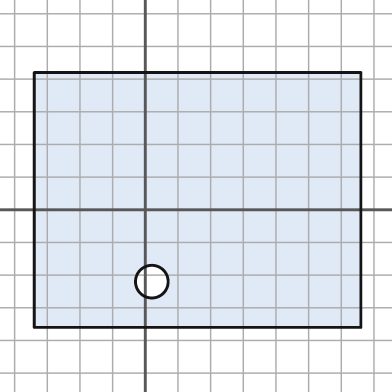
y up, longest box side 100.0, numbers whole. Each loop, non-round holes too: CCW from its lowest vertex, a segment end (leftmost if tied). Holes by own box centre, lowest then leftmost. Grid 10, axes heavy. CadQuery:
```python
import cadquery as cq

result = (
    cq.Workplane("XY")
    .moveTo(-34.0, -36.0)
    .lineTo(66.0, -36.0)
    .lineTo(66.0, 42.0)
    .lineTo(-34.0, 42.0)
    .close()
    .moveTo(2.0, -22.0)
    .circle(5.0)
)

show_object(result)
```